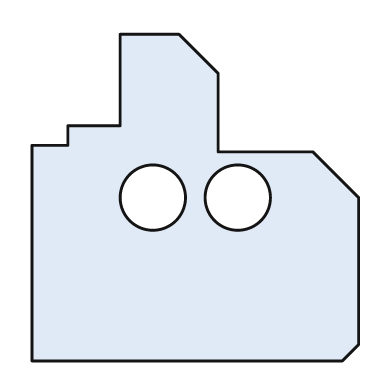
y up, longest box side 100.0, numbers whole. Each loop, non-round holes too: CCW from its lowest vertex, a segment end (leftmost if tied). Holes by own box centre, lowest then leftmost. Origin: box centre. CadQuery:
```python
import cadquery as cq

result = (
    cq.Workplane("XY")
    .moveTo(-50.0, -50.0)
    .lineTo(45.0, -50.0)
    .lineTo(50.0, -45.0)
    .lineTo(50.0, 0.0)
    .lineTo(36.0, 14.0)
    .lineTo(7.0, 14.0)
    .lineTo(7.0, 38.0)
    .lineTo(-5.0, 50.0)
    .lineTo(-23.0, 50.0)
    .lineTo(-23.0, 22.0)
    .lineTo(-39.0, 22.0)
    .lineTo(-39.0, 16.0)
    .lineTo(-50.0, 16.0)
    .close()
    .moveTo(-13.0, 0.0)
    .circle(10.0)
    .moveTo(13.0, 0.0)
    .circle(10.0)
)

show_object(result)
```